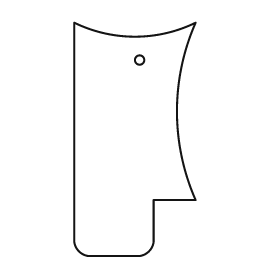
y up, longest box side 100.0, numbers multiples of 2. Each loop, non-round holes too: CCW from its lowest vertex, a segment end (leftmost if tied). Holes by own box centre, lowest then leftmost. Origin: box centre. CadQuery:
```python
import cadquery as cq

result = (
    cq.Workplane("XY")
    .moveTo(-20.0, -50.0)
    .lineTo(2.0, -50.0)
    .threePointArc((6.0, -48.0), (8.0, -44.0))
    .lineTo(8.0, -26.0)
    .lineTo(26.0, -26.0)
    .threePointArc((18.0, 12.0), (26.0, 50.0))
    .threePointArc((0.0, 44.0), (-26.0, 50.0))
    .lineTo(-26.0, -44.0)
    .threePointArc((-24.0, -48.0), (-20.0, -50.0))
    .close()
    .moveTo(2.0, 34.0)
    .circle(2.0)
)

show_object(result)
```